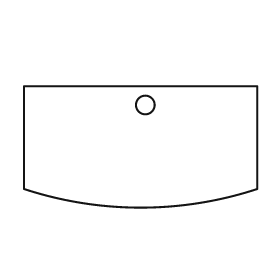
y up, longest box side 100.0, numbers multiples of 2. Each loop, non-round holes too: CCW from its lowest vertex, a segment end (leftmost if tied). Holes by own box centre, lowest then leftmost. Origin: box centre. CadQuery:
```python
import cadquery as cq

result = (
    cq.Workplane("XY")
    .moveTo(-50.0, -18.0)
    .threePointArc((0.0, -26.0), (50.0, -18.0))
    .lineTo(50.0, 26.0)
    .lineTo(-50.0, 26.0)
    .close()
    .moveTo(2.0, 18.0)
    .circle(4.0)
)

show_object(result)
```